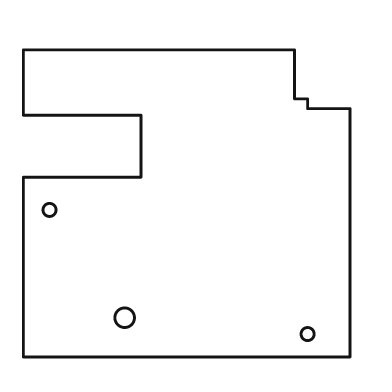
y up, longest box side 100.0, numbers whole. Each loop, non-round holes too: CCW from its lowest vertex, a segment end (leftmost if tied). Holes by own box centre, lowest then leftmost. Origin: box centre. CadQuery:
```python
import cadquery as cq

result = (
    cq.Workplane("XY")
    .moveTo(-50.0, -47.0)
    .lineTo(50.0, -47.0)
    .lineTo(50.0, 29.0)
    .lineTo(37.0, 29.0)
    .lineTo(37.0, 32.0)
    .lineTo(33.0, 32.0)
    .lineTo(33.0, 47.0)
    .lineTo(-50.0, 47.0)
    .lineTo(-50.0, 27.0)
    .lineTo(-14.0, 27.0)
    .lineTo(-14.0, 8.0)
    .lineTo(-50.0, 8.0)
    .close()
    .moveTo(37.0, -40.0)
    .circle(2.0)
    .moveTo(-19.0, -35.0)
    .circle(3.0)
    .moveTo(-42.0, -2.0)
    .circle(2.0)
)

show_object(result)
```